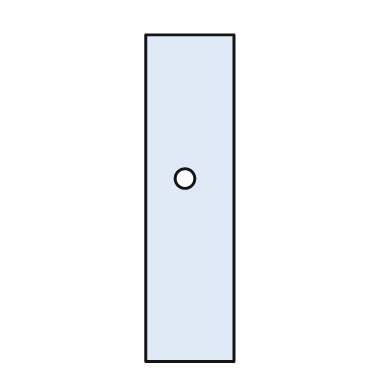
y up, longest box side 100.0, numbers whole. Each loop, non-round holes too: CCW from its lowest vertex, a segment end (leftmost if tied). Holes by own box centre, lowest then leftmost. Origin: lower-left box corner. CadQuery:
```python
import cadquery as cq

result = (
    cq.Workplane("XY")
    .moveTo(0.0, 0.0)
    .lineTo(27.0, 0.0)
    .lineTo(27.0, 100.0)
    .lineTo(0.0, 100.0)
    .close()
    .moveTo(12.0, 56.0)
    .circle(3.0)
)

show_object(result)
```